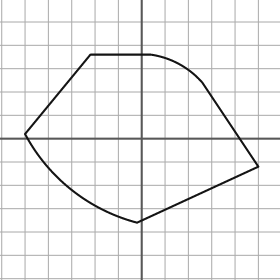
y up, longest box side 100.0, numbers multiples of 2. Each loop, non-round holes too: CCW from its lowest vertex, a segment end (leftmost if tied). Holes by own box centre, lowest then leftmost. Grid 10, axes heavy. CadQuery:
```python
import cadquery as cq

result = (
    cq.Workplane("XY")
    .moveTo(-2.0, -36.0)
    .lineTo(50.0, -12.0)
    .lineTo(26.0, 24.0)
    .threePointArc((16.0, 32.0), (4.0, 36.0))
    .lineTo(-22.0, 36.0)
    .lineTo(-50.0, 2.0)
    .threePointArc((-30.0, -22.0), (-2.0, -36.0))
    .close()
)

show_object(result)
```